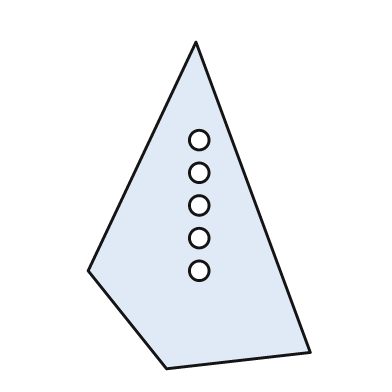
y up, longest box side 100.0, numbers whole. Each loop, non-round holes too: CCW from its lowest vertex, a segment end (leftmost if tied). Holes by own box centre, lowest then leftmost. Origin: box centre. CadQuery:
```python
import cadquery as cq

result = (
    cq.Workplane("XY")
    .moveTo(-10.0, -50.0)
    .lineTo(34.0, -45.0)
    .lineTo(-1.0, 50.0)
    .lineTo(-34.0, -20.0)
    .close()
    .moveTo(0.0, -20.0)
    .circle(3.0)
    .moveTo(0.0, -10.0)
    .circle(3.0)
    .moveTo(0.0, 0.0)
    .circle(3.0)
    .moveTo(0.0, 10.0)
    .circle(3.0)
    .moveTo(0.0, 20.0)
    .circle(3.0)
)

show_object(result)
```